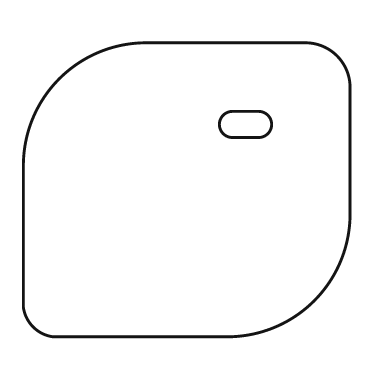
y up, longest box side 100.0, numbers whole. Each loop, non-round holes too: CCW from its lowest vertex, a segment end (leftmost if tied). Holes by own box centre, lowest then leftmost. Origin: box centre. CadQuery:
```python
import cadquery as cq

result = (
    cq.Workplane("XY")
    .moveTo(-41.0, -45.0)
    .lineTo(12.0, -45.0)
    .threePointArc((39.0, -34.0), (50.0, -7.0))
    .lineTo(50.0, 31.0)
    .threePointArc((46.0, 41.0), (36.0, 45.0))
    .lineTo(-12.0, 45.0)
    .threePointArc((-39.0, 34.0), (-50.0, 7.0))
    .lineTo(-50.0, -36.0)
    .threePointArc((-47.0, -42.0), (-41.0, -45.0))
    .close()
    .moveTo(14.0, 16.0)
    .lineTo(22.0, 16.0)
    .threePointArc((26.0, 20.0), (22.0, 24.0))
    .lineTo(14.0, 24.0)
    .threePointArc((10.0, 20.0), (14.0, 16.0))
    .close()
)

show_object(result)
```